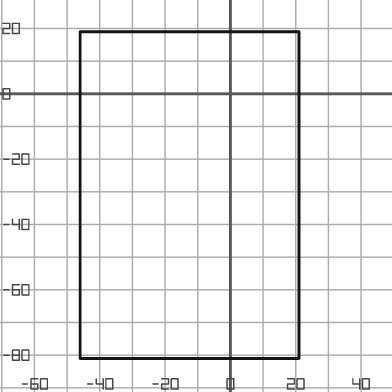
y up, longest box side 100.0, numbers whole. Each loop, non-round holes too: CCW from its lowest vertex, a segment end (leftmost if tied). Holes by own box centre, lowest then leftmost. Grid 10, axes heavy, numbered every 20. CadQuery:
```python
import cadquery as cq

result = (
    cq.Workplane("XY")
    .moveTo(-46.0, -81.0)
    .lineTo(21.0, -81.0)
    .lineTo(21.0, 19.0)
    .lineTo(-46.0, 19.0)
    .close()
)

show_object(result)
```